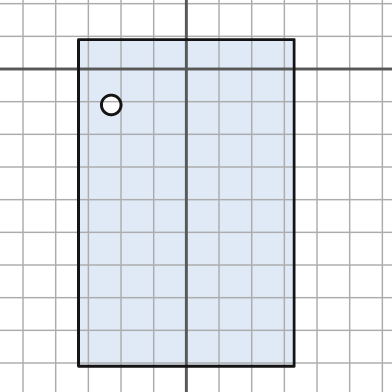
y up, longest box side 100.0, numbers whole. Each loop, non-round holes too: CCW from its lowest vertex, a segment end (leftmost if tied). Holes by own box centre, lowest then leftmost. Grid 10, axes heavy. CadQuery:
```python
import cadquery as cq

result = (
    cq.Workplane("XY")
    .moveTo(-33.0, -91.0)
    .lineTo(33.0, -91.0)
    .lineTo(33.0, 9.0)
    .lineTo(-33.0, 9.0)
    .close()
    .moveTo(-23.0, -11.0)
    .circle(3.0)
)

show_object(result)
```